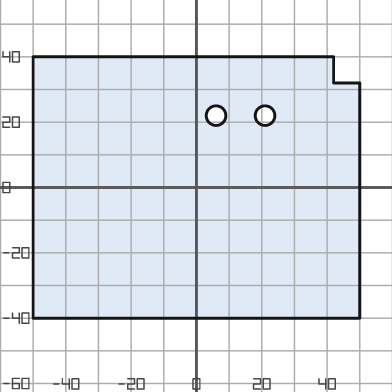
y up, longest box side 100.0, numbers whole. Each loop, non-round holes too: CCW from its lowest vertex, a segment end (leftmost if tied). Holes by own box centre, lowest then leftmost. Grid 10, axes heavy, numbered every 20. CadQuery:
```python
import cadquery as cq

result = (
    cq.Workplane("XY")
    .moveTo(-50.0, -40.0)
    .lineTo(50.0, -40.0)
    .lineTo(50.0, 32.0)
    .lineTo(42.0, 32.0)
    .lineTo(42.0, 40.0)
    .lineTo(-50.0, 40.0)
    .close()
    .moveTo(6.0, 22.0)
    .circle(3.0)
    .moveTo(21.0, 22.0)
    .circle(3.0)
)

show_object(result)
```